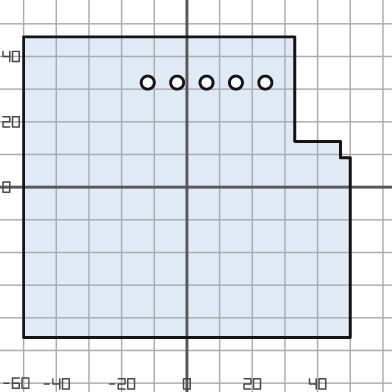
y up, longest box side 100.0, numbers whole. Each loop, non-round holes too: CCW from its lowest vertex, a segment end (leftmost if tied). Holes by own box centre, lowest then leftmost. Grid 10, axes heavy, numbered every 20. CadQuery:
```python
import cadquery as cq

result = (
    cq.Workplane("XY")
    .moveTo(-50.0, -46.0)
    .lineTo(50.0, -46.0)
    .lineTo(50.0, 9.0)
    .lineTo(47.0, 9.0)
    .lineTo(47.0, 14.0)
    .lineTo(33.0, 14.0)
    .lineTo(33.0, 46.0)
    .lineTo(-50.0, 46.0)
    .close()
    .moveTo(-12.0, 32.0)
    .circle(2.0)
    .moveTo(-3.0, 32.0)
    .circle(2.0)
    .moveTo(6.0, 32.0)
    .circle(2.0)
    .moveTo(15.0, 32.0)
    .circle(2.0)
    .moveTo(24.0, 32.0)
    .circle(2.0)
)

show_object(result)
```